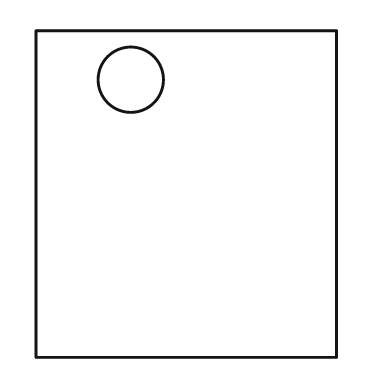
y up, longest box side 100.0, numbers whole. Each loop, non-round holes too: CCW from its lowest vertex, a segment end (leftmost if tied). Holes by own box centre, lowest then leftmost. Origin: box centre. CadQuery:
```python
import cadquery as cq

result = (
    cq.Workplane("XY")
    .moveTo(-46.0, -50.0)
    .lineTo(46.0, -50.0)
    .lineTo(46.0, 50.0)
    .lineTo(-46.0, 50.0)
    .close()
    .moveTo(-17.0, 35.0)
    .circle(10.0)
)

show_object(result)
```